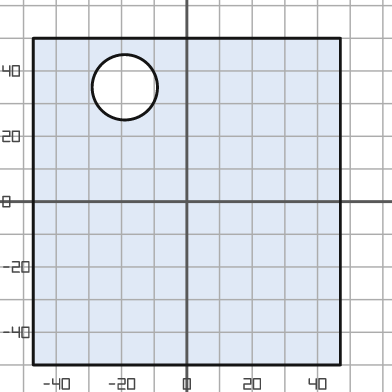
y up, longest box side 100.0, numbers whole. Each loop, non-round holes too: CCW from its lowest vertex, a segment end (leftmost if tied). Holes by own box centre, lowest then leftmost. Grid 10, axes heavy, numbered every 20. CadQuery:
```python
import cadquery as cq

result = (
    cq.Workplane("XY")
    .moveTo(-47.0, -50.0)
    .lineTo(47.0, -50.0)
    .lineTo(47.0, 50.0)
    .lineTo(-47.0, 50.0)
    .close()
    .moveTo(-19.0, 35.0)
    .circle(10.0)
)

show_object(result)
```